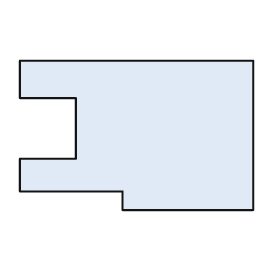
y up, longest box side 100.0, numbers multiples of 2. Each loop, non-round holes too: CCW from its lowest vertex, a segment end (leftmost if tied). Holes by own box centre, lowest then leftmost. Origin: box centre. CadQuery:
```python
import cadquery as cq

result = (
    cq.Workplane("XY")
    .moveTo(-6.0, -32.0)
    .lineTo(50.0, -32.0)
    .lineTo(50.0, 32.0)
    .lineTo(-50.0, 32.0)
    .lineTo(-50.0, 16.0)
    .lineTo(-26.0, 16.0)
    .lineTo(-26.0, -10.0)
    .lineTo(-50.0, -10.0)
    .lineTo(-50.0, -24.0)
    .lineTo(-6.0, -24.0)
    .close()
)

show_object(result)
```